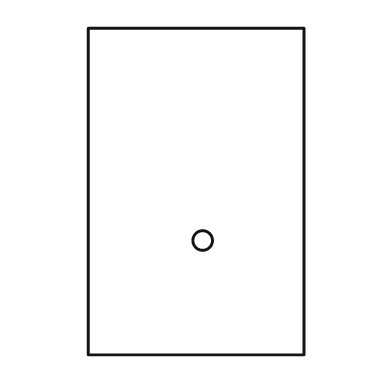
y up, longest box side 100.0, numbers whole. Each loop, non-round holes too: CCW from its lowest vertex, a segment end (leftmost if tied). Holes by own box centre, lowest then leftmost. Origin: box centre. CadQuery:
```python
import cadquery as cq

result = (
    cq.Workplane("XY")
    .moveTo(-33.0, -50.0)
    .lineTo(33.0, -50.0)
    .lineTo(33.0, 50.0)
    .lineTo(-33.0, 50.0)
    .close()
    .moveTo(2.0, -15.0)
    .circle(3.0)
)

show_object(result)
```